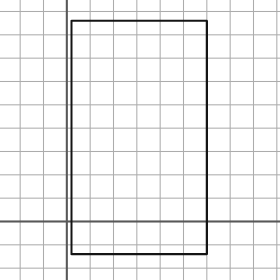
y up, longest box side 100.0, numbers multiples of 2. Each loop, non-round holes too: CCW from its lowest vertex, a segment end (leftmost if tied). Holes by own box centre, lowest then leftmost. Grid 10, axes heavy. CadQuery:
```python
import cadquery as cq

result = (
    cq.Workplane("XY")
    .moveTo(2.0, -14.0)
    .lineTo(60.0, -14.0)
    .lineTo(60.0, 86.0)
    .lineTo(2.0, 86.0)
    .close()
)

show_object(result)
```